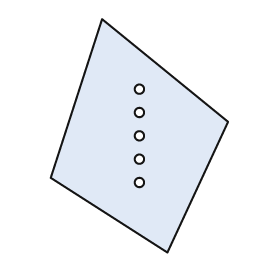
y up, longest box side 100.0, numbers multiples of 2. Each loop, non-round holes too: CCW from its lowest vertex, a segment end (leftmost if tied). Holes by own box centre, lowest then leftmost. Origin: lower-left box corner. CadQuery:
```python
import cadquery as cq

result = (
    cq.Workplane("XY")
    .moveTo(50.0, 0.0)
    .lineTo(76.0, 56.0)
    .lineTo(22.0, 100.0)
    .lineTo(0.0, 32.0)
    .close()
    .moveTo(38.0, 30.0)
    .circle(2.0)
    .moveTo(38.0, 40.0)
    .circle(2.0)
    .moveTo(38.0, 50.0)
    .circle(2.0)
    .moveTo(38.0, 60.0)
    .circle(2.0)
    .moveTo(38.0, 70.0)
    .circle(2.0)
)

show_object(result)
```